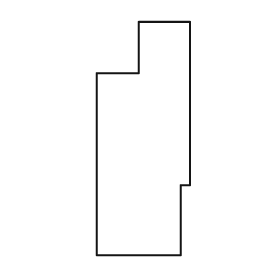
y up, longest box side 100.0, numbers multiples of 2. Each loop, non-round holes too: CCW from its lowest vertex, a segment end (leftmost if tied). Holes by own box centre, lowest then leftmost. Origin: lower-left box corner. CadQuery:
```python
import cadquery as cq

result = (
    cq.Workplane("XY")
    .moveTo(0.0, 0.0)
    .lineTo(36.0, 0.0)
    .lineTo(36.0, 30.0)
    .lineTo(40.0, 30.0)
    .lineTo(40.0, 100.0)
    .lineTo(18.0, 100.0)
    .lineTo(18.0, 78.0)
    .lineTo(0.0, 78.0)
    .close()
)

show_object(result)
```